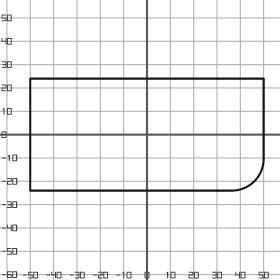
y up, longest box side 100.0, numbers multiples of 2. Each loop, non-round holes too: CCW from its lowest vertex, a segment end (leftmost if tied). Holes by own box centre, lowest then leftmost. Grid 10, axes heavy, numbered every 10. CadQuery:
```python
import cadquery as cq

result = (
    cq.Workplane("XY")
    .moveTo(-50.0, -24.0)
    .lineTo(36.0, -24.0)
    .threePointArc((46.0, -20.0), (50.0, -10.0))
    .lineTo(50.0, 24.0)
    .lineTo(-50.0, 24.0)
    .close()
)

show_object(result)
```